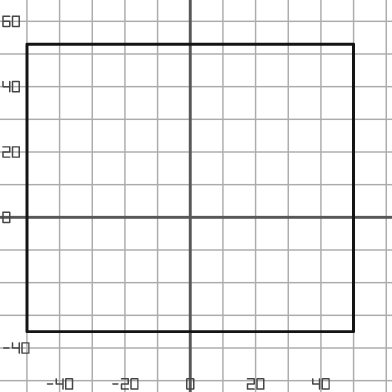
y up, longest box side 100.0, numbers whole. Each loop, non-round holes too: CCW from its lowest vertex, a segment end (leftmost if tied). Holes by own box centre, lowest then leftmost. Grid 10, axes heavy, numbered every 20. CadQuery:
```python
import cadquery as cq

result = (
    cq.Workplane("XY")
    .moveTo(-50.0, -35.0)
    .lineTo(50.0, -35.0)
    .lineTo(50.0, 53.0)
    .lineTo(-50.0, 53.0)
    .close()
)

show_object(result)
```